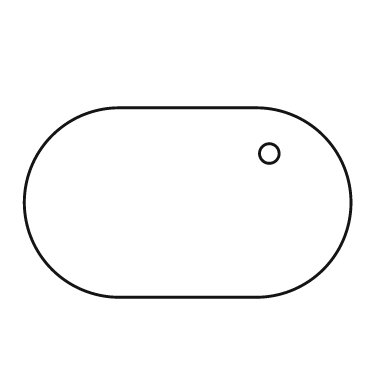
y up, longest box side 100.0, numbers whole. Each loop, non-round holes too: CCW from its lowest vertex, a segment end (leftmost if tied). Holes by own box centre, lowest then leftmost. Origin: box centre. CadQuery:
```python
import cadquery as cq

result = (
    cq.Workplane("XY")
    .moveTo(-21.0, -29.0)
    .lineTo(21.0, -29.0)
    .threePointArc((50.0, 0.0), (21.0, 29.0))
    .lineTo(-21.0, 29.0)
    .threePointArc((-50.0, 0.0), (-21.0, -29.0))
    .close()
    .moveTo(25.0, 15.0)
    .circle(3.0)
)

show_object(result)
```